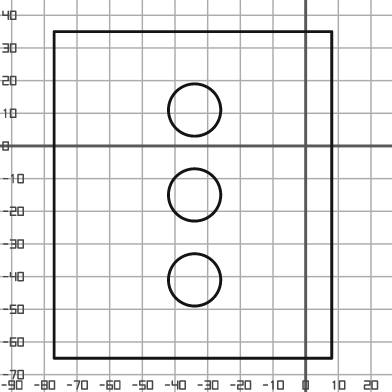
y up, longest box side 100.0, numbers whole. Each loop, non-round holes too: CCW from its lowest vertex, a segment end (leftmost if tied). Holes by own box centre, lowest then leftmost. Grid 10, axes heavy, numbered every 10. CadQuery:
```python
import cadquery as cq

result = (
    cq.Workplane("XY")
    .moveTo(-77.0, -65.0)
    .lineTo(8.0, -65.0)
    .lineTo(8.0, 35.0)
    .lineTo(-77.0, 35.0)
    .close()
    .moveTo(-34.0, -41.0)
    .circle(8.0)
    .moveTo(-34.0, -15.0)
    .circle(8.0)
    .moveTo(-34.0, 11.0)
    .circle(8.0)
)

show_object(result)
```